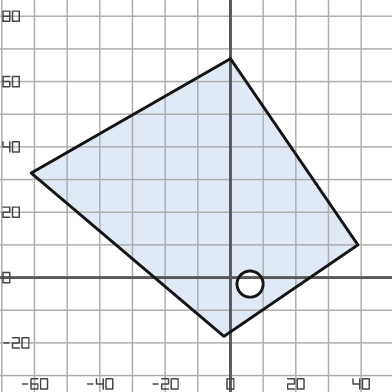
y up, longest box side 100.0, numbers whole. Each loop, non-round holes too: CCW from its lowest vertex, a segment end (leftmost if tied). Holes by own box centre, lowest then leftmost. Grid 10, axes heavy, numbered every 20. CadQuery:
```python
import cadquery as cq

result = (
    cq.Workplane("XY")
    .moveTo(-2.0, -18.0)
    .lineTo(39.0, 10.0)
    .lineTo(0.0, 67.0)
    .lineTo(-61.0, 32.0)
    .close()
    .moveTo(6.0, -2.0)
    .circle(4.0)
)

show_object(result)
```